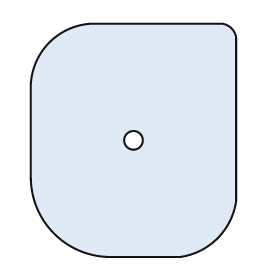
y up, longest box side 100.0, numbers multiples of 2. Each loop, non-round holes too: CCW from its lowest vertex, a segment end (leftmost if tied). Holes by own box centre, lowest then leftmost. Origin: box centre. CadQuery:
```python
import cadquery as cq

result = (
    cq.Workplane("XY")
    .moveTo(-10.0, -50.0)
    .lineTo(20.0, -50.0)
    .threePointArc((36.0, -42.0), (44.0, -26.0))
    .lineTo(44.0, 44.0)
    .threePointArc((42.0, 48.0), (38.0, 50.0))
    .lineTo(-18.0, 50.0)
    .threePointArc((-36.0, 42.0), (-44.0, 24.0))
    .lineTo(-44.0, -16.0)
    .threePointArc((-34.0, -40.0), (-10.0, -50.0))
    .close()
    .moveTo(0.0, 0.0)
    .circle(4.0)
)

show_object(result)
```